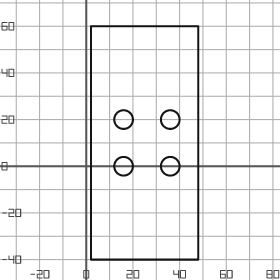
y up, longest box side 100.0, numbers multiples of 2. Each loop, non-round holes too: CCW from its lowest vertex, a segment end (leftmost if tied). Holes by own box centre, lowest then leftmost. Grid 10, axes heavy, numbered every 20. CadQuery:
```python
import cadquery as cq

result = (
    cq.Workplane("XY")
    .moveTo(2.0, -40.0)
    .lineTo(48.0, -40.0)
    .lineTo(48.0, 60.0)
    .lineTo(2.0, 60.0)
    .close()
    .moveTo(16.0, 0.0)
    .circle(4.0)
    .moveTo(36.0, 0.0)
    .circle(4.0)
    .moveTo(16.0, 20.0)
    .circle(4.0)
    .moveTo(36.0, 20.0)
    .circle(4.0)
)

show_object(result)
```